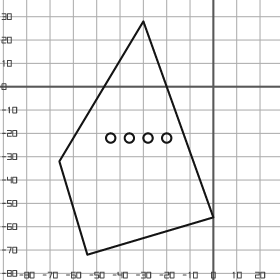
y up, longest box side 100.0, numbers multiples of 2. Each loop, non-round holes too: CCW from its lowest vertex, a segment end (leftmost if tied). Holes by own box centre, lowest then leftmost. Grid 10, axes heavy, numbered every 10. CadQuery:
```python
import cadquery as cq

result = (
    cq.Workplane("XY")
    .moveTo(-54.0, -72.0)
    .lineTo(0.0, -56.0)
    .lineTo(-30.0, 28.0)
    .lineTo(-66.0, -32.0)
    .close()
    .moveTo(-44.0, -22.0)
    .circle(2.0)
    .moveTo(-36.0, -22.0)
    .circle(2.0)
    .moveTo(-28.0, -22.0)
    .circle(2.0)
    .moveTo(-20.0, -22.0)
    .circle(2.0)
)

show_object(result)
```